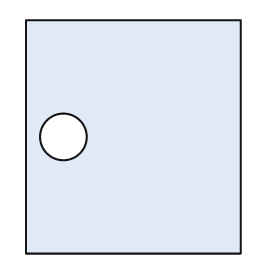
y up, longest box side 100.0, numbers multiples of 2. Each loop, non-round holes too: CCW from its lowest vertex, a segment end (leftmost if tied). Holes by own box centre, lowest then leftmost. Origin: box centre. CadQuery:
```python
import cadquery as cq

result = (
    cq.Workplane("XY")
    .moveTo(-46.0, -50.0)
    .lineTo(46.0, -50.0)
    .lineTo(46.0, 50.0)
    .lineTo(-46.0, 50.0)
    .close()
    .moveTo(-30.0, 0.0)
    .circle(10.0)
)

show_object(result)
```